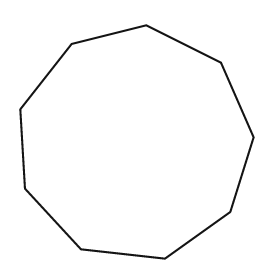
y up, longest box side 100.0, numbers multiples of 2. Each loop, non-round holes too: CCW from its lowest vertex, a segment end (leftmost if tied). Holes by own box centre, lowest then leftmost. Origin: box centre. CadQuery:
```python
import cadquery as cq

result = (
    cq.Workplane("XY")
    .moveTo(12.0, -50.0)
    .lineTo(40.0, -30.0)
    .lineTo(50.0, 2.0)
    .lineTo(36.0, 34.0)
    .lineTo(4.0, 50.0)
    .lineTo(-28.0, 42.0)
    .lineTo(-50.0, 14.0)
    .lineTo(-48.0, -20.0)
    .lineTo(-24.0, -46.0)
    .close()
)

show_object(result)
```